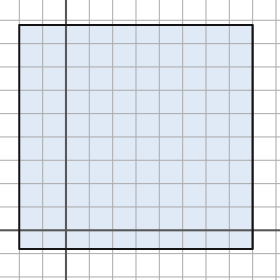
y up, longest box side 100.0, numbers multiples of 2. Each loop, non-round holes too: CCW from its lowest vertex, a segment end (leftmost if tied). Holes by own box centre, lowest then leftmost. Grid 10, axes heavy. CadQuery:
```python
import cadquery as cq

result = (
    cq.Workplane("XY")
    .moveTo(-20.0, -8.0)
    .lineTo(80.0, -8.0)
    .lineTo(80.0, 88.0)
    .lineTo(-20.0, 88.0)
    .close()
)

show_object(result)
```